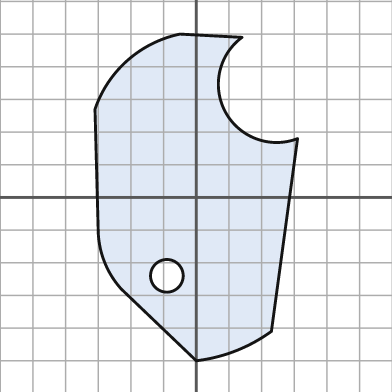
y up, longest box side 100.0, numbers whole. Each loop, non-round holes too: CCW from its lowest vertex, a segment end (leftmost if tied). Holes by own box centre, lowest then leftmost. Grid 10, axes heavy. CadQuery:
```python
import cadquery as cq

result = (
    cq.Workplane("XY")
    .moveTo(0.0, -50.0)
    .threePointArc((12.0, -47.0), (23.0, -41.0))
    .lineTo(31.0, 18.0)
    .threePointArc((9.0, 26.0), (14.0, 49.0))
    .lineTo(-5.0, 50.0)
    .threePointArc((-21.0, 42.0), (-31.0, 27.0))
    .lineTo(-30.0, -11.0)
    .threePointArc((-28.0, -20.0), (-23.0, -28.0))
    .close()
    .moveTo(-9.0, -24.0)
    .circle(5.0)
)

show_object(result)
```